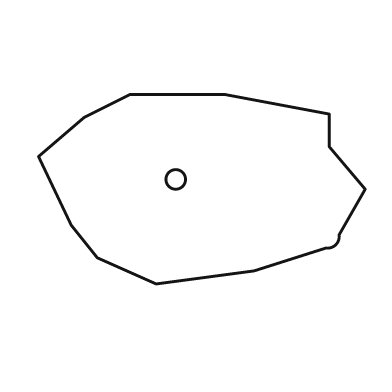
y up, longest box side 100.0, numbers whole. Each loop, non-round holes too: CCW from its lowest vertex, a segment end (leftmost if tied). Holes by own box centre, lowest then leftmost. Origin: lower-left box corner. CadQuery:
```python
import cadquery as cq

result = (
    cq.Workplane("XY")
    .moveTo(36.0, 0.0)
    .lineTo(66.0, 4.0)
    .lineTo(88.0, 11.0)
    .threePointArc((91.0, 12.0), (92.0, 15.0))
    .lineTo(100.0, 29.0)
    .lineTo(89.0, 42.0)
    .lineTo(89.0, 52.0)
    .lineTo(57.0, 58.0)
    .lineTo(28.0, 58.0)
    .lineTo(14.0, 51.0)
    .lineTo(0.0, 39.0)
    .lineTo(10.0, 18.0)
    .lineTo(18.0, 8.0)
    .close()
    .moveTo(42.0, 32.0)
    .circle(3.0)
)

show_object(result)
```